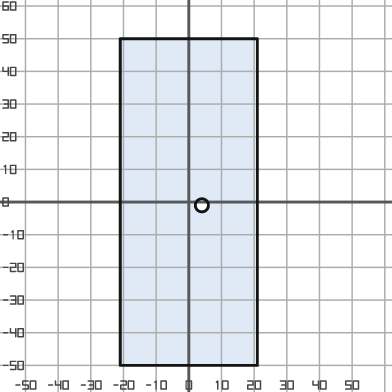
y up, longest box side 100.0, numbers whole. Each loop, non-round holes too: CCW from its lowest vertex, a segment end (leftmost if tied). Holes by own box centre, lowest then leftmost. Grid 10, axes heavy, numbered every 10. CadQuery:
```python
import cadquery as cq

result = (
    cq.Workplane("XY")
    .moveTo(-21.0, -50.0)
    .lineTo(21.0, -50.0)
    .lineTo(21.0, 50.0)
    .lineTo(-21.0, 50.0)
    .close()
    .moveTo(4.0, -1.0)
    .circle(2.0)
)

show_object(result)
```